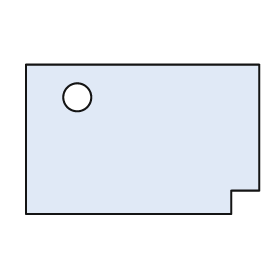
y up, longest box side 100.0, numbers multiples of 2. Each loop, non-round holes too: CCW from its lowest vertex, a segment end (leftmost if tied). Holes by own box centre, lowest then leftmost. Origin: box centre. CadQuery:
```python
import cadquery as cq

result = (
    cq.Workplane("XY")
    .moveTo(-50.0, -32.0)
    .lineTo(38.0, -32.0)
    .lineTo(38.0, -22.0)
    .lineTo(50.0, -22.0)
    .lineTo(50.0, 32.0)
    .lineTo(-50.0, 32.0)
    .close()
    .moveTo(-28.0, 18.0)
    .circle(6.0)
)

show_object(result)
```